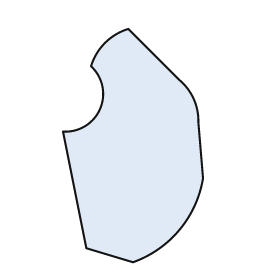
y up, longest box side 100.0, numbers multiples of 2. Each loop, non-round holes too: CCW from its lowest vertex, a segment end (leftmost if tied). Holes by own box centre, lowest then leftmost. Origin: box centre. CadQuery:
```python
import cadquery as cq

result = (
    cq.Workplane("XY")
    .moveTo(0.0, -50.0)
    .threePointArc((20.0, -36.0), (30.0, -14.0))
    .lineTo(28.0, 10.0)
    .threePointArc((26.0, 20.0), (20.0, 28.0))
    .lineTo(-2.0, 50.0)
    .threePointArc((-12.0, 44.0), (-18.0, 34.0))
    .threePointArc((-14.0, 16.0), (-30.0, 6.0))
    .lineTo(-20.0, -44.0)
    .close()
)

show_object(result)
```